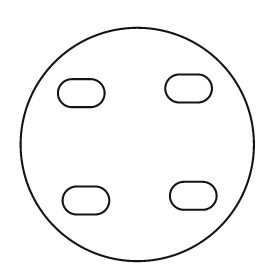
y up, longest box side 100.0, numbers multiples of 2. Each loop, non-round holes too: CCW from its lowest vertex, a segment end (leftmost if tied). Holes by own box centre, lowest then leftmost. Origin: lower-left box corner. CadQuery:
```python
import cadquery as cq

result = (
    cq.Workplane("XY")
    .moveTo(50.0, 50.0)
    .circle(50.0)
    .moveTo(24.0, 20.0)
    .lineTo(32.0, 20.0)
    .threePointArc((38.0, 26.0), (32.0, 32.0))
    .lineTo(24.0, 32.0)
    .threePointArc((18.0, 26.0), (24.0, 20.0))
    .close()
    .moveTo(70.0, 22.0)
    .lineTo(78.0, 22.0)
    .threePointArc((84.0, 28.0), (78.0, 34.0))
    .lineTo(70.0, 34.0)
    .threePointArc((64.0, 28.0), (70.0, 22.0))
    .close()
    .moveTo(22.0, 66.0)
    .lineTo(30.0, 66.0)
    .threePointArc((36.0, 72.0), (30.0, 78.0))
    .lineTo(22.0, 78.0)
    .threePointArc((16.0, 72.0), (22.0, 66.0))
    .close()
    .moveTo(68.0, 68.0)
    .lineTo(76.0, 68.0)
    .threePointArc((82.0, 74.0), (76.0, 80.0))
    .lineTo(68.0, 80.0)
    .threePointArc((62.0, 74.0), (68.0, 68.0))
    .close()
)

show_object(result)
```